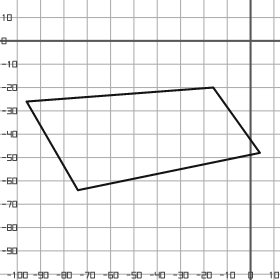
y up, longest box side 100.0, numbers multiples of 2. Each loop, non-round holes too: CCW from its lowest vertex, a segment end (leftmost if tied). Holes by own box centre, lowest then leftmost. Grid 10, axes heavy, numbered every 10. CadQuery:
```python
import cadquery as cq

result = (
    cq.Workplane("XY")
    .moveTo(-74.0, -64.0)
    .lineTo(4.0, -48.0)
    .lineTo(-16.0, -20.0)
    .lineTo(-96.0, -26.0)
    .close()
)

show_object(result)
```